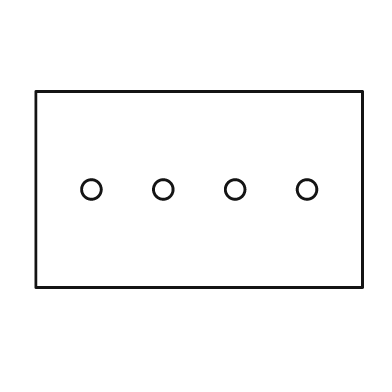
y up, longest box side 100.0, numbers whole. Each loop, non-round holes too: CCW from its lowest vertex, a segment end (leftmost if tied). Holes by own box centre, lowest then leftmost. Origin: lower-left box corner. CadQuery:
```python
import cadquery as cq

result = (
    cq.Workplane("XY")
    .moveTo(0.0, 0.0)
    .lineTo(100.0, 0.0)
    .lineTo(100.0, 60.0)
    .lineTo(0.0, 60.0)
    .close()
    .moveTo(17.0, 30.0)
    .circle(3.0)
    .moveTo(39.0, 30.0)
    .circle(3.0)
    .moveTo(61.0, 30.0)
    .circle(3.0)
    .moveTo(83.0, 30.0)
    .circle(3.0)
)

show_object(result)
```